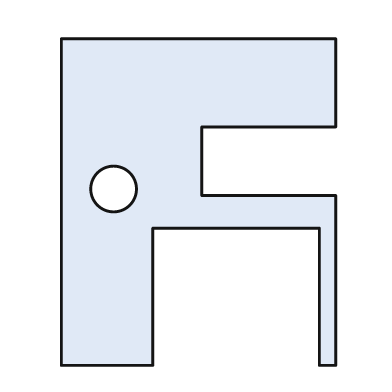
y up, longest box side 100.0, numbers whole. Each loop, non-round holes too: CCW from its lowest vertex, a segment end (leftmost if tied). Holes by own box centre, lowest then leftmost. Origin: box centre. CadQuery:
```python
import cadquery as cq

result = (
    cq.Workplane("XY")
    .moveTo(-42.0, -50.0)
    .lineTo(-14.0, -50.0)
    .lineTo(-14.0, -8.0)
    .lineTo(37.0, -8.0)
    .lineTo(37.0, -50.0)
    .lineTo(42.0, -50.0)
    .lineTo(42.0, 2.0)
    .lineTo(1.0, 2.0)
    .lineTo(1.0, 23.0)
    .lineTo(42.0, 23.0)
    .lineTo(42.0, 50.0)
    .lineTo(-42.0, 50.0)
    .close()
    .moveTo(-26.0, 4.0)
    .circle(7.0)
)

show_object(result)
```